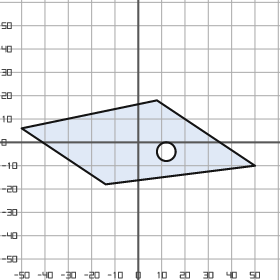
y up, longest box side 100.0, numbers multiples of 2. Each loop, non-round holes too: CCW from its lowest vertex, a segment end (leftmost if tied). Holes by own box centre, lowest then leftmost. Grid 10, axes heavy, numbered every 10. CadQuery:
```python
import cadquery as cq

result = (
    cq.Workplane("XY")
    .moveTo(-14.0, -18.0)
    .lineTo(50.0, -10.0)
    .lineTo(8.0, 18.0)
    .lineTo(-50.0, 6.0)
    .close()
    .moveTo(12.0, -4.0)
    .circle(4.0)
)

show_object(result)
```